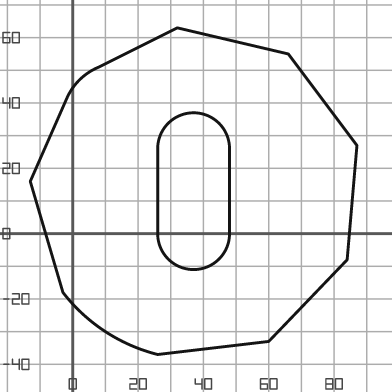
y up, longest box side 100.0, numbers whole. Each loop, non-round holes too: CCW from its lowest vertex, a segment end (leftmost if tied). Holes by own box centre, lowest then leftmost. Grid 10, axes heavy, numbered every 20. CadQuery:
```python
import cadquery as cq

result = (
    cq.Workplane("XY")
    .moveTo(26.0, -37.0)
    .lineTo(60.0, -33.0)
    .lineTo(84.0, -8.0)
    .lineTo(87.0, 27.0)
    .lineTo(66.0, 55.0)
    .lineTo(32.0, 63.0)
    .lineTo(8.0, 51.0)
    .threePointArc((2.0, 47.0), (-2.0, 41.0))
    .lineTo(-13.0, 16.0)
    .lineTo(-3.0, -18.0)
    .threePointArc((10.0, -30.0), (26.0, -37.0))
    .close()
    .moveTo(26.0, 0.0)
    .threePointArc((37.0, -11.0), (48.0, 0.0))
    .lineTo(48.0, 26.0)
    .threePointArc((37.0, 37.0), (26.0, 26.0))
    .close()
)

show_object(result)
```